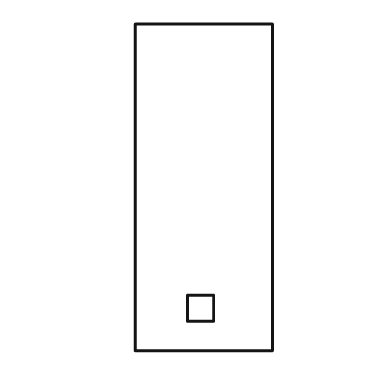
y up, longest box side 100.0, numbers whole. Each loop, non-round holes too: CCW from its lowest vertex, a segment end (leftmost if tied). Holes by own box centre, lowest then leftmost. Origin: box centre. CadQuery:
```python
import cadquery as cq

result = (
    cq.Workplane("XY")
    .moveTo(-21.0, -50.0)
    .lineTo(21.0, -50.0)
    .lineTo(21.0, 50.0)
    .lineTo(-21.0, 50.0)
    .close()
    .moveTo(-5.0, -41.0)
    .lineTo(3.0, -41.0)
    .lineTo(3.0, -33.0)
    .lineTo(-5.0, -33.0)
    .close()
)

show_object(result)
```